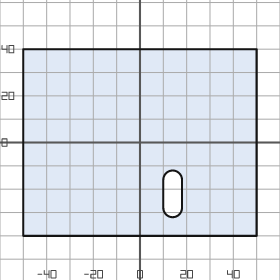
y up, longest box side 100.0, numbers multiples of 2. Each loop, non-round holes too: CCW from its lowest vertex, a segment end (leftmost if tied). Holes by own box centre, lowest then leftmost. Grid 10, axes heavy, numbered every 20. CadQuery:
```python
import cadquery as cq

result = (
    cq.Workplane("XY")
    .moveTo(-50.0, -40.0)
    .lineTo(50.0, -40.0)
    .lineTo(50.0, 40.0)
    .lineTo(-50.0, 40.0)
    .close()
    .moveTo(10.0, -28.0)
    .threePointArc((14.0, -32.0), (18.0, -28.0))
    .lineTo(18.0, -16.0)
    .threePointArc((14.0, -12.0), (10.0, -16.0))
    .close()
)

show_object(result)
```